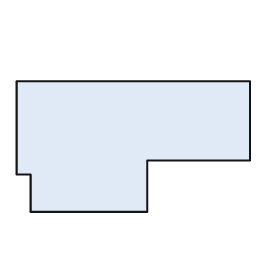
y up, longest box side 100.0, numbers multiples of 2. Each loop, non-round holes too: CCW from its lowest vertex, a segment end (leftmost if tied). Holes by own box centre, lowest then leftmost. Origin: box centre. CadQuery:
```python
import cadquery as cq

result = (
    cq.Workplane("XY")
    .moveTo(-44.0, -28.0)
    .lineTo(6.0, -28.0)
    .lineTo(6.0, -6.0)
    .lineTo(50.0, -6.0)
    .lineTo(50.0, 28.0)
    .lineTo(-50.0, 28.0)
    .lineTo(-50.0, -12.0)
    .lineTo(-44.0, -12.0)
    .close()
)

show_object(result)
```